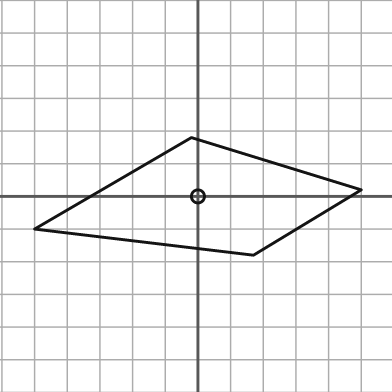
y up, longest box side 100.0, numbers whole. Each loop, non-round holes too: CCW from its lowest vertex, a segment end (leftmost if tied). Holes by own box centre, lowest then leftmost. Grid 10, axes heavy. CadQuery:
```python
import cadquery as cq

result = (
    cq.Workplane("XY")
    .moveTo(17.0, -18.0)
    .lineTo(50.0, 2.0)
    .lineTo(-2.0, 18.0)
    .lineTo(-50.0, -10.0)
    .close()
    .moveTo(0.0, 0.0)
    .circle(2.0)
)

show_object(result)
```